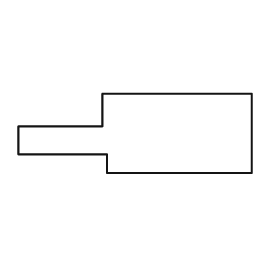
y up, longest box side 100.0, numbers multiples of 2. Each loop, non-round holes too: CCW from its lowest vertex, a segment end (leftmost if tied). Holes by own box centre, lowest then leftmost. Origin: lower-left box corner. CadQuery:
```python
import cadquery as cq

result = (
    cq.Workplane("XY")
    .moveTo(38.0, 0.0)
    .lineTo(100.0, 0.0)
    .lineTo(100.0, 34.0)
    .lineTo(36.0, 34.0)
    .lineTo(36.0, 20.0)
    .lineTo(0.0, 20.0)
    .lineTo(0.0, 8.0)
    .lineTo(38.0, 8.0)
    .close()
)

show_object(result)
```